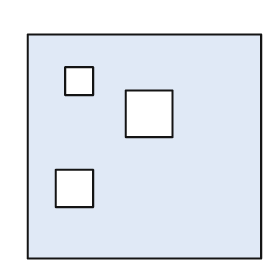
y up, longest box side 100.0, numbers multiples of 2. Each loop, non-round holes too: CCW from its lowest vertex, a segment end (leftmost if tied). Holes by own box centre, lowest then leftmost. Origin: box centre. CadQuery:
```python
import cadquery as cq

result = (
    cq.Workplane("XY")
    .moveTo(-50.0, -48.0)
    .lineTo(50.0, -48.0)
    .lineTo(50.0, 48.0)
    .lineTo(-50.0, 48.0)
    .close()
    .moveTo(-38.0, -26.0)
    .lineTo(-22.0, -26.0)
    .lineTo(-22.0, -10.0)
    .lineTo(-38.0, -10.0)
    .close()
    .moveTo(-8.0, 4.0)
    .lineTo(12.0, 4.0)
    .lineTo(12.0, 24.0)
    .lineTo(-8.0, 24.0)
    .close()
    .moveTo(-34.0, 22.0)
    .lineTo(-22.0, 22.0)
    .lineTo(-22.0, 34.0)
    .lineTo(-34.0, 34.0)
    .close()
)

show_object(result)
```